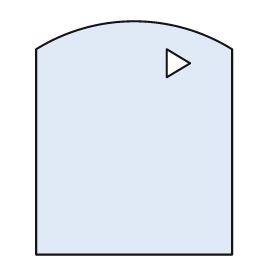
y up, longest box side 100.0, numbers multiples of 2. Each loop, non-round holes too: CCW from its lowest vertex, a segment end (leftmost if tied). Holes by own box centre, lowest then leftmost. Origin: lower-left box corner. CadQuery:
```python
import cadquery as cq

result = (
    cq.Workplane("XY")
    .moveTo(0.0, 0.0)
    .lineTo(84.0, 0.0)
    .lineTo(84.0, 88.0)
    .threePointArc((42.0, 100.0), (0.0, 88.0))
    .close()
    .moveTo(56.0, 76.0)
    .lineTo(66.0, 82.0)
    .lineTo(56.0, 88.0)
    .close()
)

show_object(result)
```